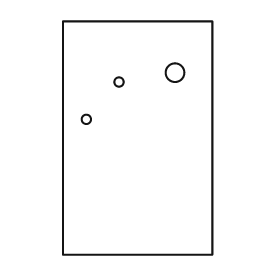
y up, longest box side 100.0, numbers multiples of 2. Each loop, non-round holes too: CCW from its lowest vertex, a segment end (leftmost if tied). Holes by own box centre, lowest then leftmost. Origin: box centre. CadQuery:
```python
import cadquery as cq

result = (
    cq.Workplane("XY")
    .moveTo(-32.0, -50.0)
    .lineTo(32.0, -50.0)
    .lineTo(32.0, 50.0)
    .lineTo(-32.0, 50.0)
    .close()
    .moveTo(-22.0, 8.0)
    .circle(2.0)
    .moveTo(-8.0, 24.0)
    .circle(2.0)
    .moveTo(16.0, 28.0)
    .circle(4.0)
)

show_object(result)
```